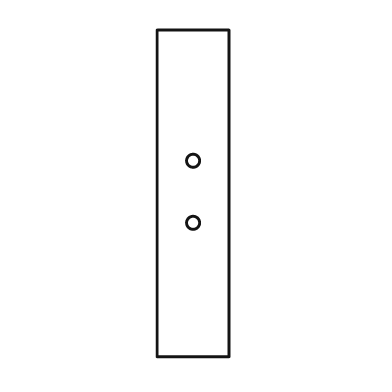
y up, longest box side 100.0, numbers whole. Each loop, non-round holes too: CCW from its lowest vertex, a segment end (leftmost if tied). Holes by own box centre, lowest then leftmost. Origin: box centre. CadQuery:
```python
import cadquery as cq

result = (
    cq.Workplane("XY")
    .moveTo(-11.0, -50.0)
    .lineTo(11.0, -50.0)
    .lineTo(11.0, 50.0)
    .lineTo(-11.0, 50.0)
    .close()
    .moveTo(0.0, -9.0)
    .circle(2.0)
    .moveTo(0.0, 10.0)
    .circle(2.0)
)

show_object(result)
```